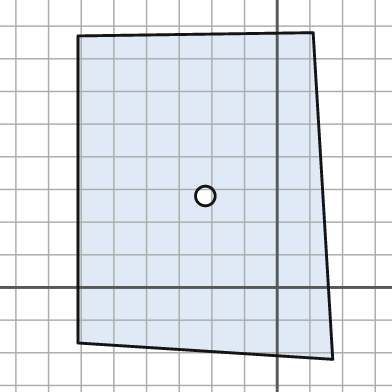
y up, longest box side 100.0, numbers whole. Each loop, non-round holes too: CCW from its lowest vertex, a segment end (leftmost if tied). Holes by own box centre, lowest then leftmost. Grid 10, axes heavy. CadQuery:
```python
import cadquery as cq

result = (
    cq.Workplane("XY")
    .moveTo(17.0, -22.0)
    .lineTo(11.0, 78.0)
    .lineTo(-61.0, 77.0)
    .lineTo(-61.0, -17.0)
    .close()
    .moveTo(-22.0, 28.0)
    .circle(3.0)
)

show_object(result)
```